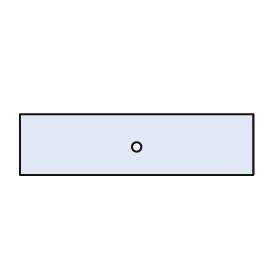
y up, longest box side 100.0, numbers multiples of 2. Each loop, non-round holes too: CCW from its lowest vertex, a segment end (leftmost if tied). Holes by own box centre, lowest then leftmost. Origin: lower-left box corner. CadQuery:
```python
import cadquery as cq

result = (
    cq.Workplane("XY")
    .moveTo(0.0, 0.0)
    .lineTo(100.0, 0.0)
    .lineTo(100.0, 26.0)
    .lineTo(0.0, 26.0)
    .close()
    .moveTo(50.0, 12.0)
    .circle(2.0)
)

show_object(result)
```